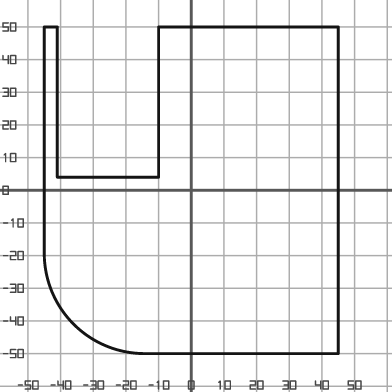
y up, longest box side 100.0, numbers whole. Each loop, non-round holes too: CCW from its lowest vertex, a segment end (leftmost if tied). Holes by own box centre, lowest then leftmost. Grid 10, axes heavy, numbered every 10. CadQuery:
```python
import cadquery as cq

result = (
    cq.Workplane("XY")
    .moveTo(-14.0, -50.0)
    .lineTo(45.0, -50.0)
    .lineTo(45.0, 50.0)
    .lineTo(-10.0, 50.0)
    .lineTo(-10.0, 4.0)
    .lineTo(-41.0, 4.0)
    .lineTo(-41.0, 50.0)
    .lineTo(-45.0, 50.0)
    .lineTo(-45.0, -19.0)
    .threePointArc((-36.0, -41.0), (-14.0, -50.0))
    .close()
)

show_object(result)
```